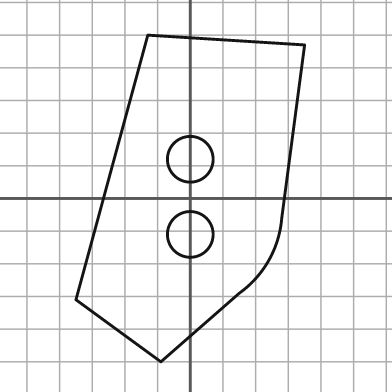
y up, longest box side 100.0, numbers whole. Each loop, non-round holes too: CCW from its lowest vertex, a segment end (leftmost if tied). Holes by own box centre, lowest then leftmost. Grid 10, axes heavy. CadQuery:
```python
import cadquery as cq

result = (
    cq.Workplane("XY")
    .moveTo(-9.0, -50.0)
    .lineTo(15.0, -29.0)
    .threePointArc((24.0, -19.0), (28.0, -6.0))
    .lineTo(35.0, 47.0)
    .lineTo(-13.0, 50.0)
    .lineTo(-35.0, -31.0)
    .close()
    .moveTo(0.0, -11.0)
    .circle(7.0)
    .moveTo(0.0, 12.0)
    .circle(7.0)
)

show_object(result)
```